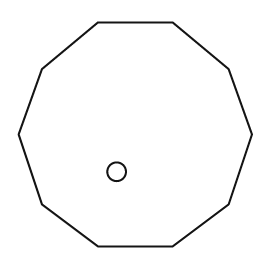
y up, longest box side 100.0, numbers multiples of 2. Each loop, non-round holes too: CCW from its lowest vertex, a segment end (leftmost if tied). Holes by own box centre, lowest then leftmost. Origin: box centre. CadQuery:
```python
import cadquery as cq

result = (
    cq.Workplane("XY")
    .moveTo(-16.0, -48.0)
    .lineTo(16.0, -48.0)
    .lineTo(40.0, -30.0)
    .lineTo(50.0, 0.0)
    .lineTo(40.0, 28.0)
    .lineTo(16.0, 48.0)
    .lineTo(-16.0, 48.0)
    .lineTo(-40.0, 28.0)
    .lineTo(-50.0, 0.0)
    .lineTo(-40.0, -30.0)
    .close()
    .moveTo(-8.0, -16.0)
    .circle(4.0)
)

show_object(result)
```